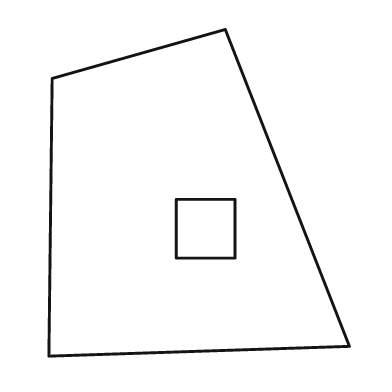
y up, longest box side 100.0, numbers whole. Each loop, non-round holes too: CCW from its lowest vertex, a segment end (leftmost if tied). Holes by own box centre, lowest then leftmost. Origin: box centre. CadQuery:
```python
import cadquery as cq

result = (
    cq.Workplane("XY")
    .moveTo(-46.0, -50.0)
    .lineTo(46.0, -47.0)
    .lineTo(8.0, 50.0)
    .lineTo(-45.0, 35.0)
    .close()
    .moveTo(-7.0, -20.0)
    .lineTo(11.0, -20.0)
    .lineTo(11.0, -2.0)
    .lineTo(-7.0, -2.0)
    .close()
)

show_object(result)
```